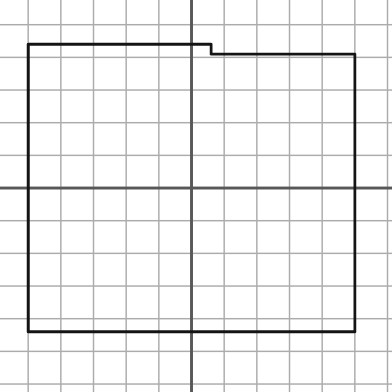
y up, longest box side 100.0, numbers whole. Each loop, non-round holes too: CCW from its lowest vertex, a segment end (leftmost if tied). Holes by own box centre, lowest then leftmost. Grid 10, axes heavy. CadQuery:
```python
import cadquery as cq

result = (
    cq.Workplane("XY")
    .moveTo(-50.0, -44.0)
    .lineTo(50.0, -44.0)
    .lineTo(50.0, 41.0)
    .lineTo(6.0, 41.0)
    .lineTo(6.0, 44.0)
    .lineTo(-50.0, 44.0)
    .close()
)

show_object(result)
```